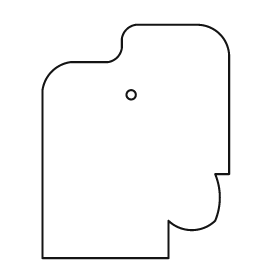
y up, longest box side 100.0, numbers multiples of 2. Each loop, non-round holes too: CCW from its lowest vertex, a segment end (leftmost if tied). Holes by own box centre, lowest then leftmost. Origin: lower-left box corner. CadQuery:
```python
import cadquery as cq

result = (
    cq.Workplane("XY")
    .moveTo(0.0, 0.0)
    .lineTo(54.0, 0.0)
    .lineTo(54.0, 16.0)
    .threePointArc((64.0, 12.0), (74.0, 16.0))
    .threePointArc((76.0, 26.0), (74.0, 36.0))
    .lineTo(80.0, 36.0)
    .lineTo(80.0, 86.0)
    .threePointArc((76.0, 96.0), (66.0, 100.0))
    .lineTo(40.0, 100.0)
    .threePointArc((36.0, 98.0), (34.0, 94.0))
    .lineTo(34.0, 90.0)
    .threePointArc((32.0, 86.0), (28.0, 84.0))
    .lineTo(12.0, 84.0)
    .threePointArc((4.0, 80.0), (0.0, 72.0))
    .close()
    .moveTo(38.0, 70.0)
    .circle(2.0)
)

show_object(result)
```